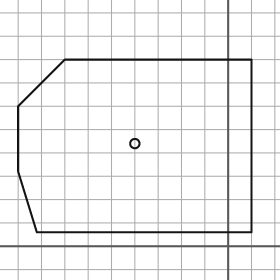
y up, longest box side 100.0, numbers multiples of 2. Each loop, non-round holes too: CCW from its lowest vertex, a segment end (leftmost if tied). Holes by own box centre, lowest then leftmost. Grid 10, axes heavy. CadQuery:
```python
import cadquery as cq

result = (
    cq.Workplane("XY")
    .moveTo(-82.0, 6.0)
    .lineTo(10.0, 6.0)
    .lineTo(10.0, 80.0)
    .lineTo(-70.0, 80.0)
    .lineTo(-90.0, 60.0)
    .lineTo(-90.0, 32.0)
    .close()
    .moveTo(-40.0, 44.0)
    .circle(2.0)
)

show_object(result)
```